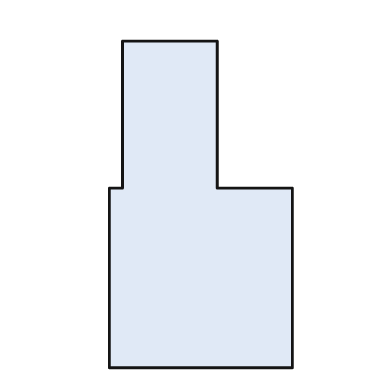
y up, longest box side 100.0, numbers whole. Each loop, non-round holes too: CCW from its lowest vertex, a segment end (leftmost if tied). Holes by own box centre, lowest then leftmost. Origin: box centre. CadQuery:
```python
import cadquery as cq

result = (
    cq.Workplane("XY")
    .moveTo(-28.0, -50.0)
    .lineTo(28.0, -50.0)
    .lineTo(28.0, 5.0)
    .lineTo(5.0, 5.0)
    .lineTo(5.0, 50.0)
    .lineTo(-24.0, 50.0)
    .lineTo(-24.0, 5.0)
    .lineTo(-28.0, 5.0)
    .close()
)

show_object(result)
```